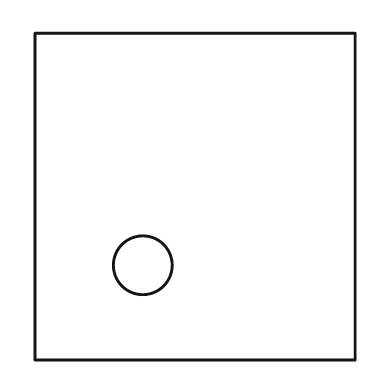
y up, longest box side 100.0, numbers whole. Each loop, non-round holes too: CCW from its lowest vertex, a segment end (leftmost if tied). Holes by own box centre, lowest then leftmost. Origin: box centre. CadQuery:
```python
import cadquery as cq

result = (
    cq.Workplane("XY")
    .moveTo(-49.0, -50.0)
    .lineTo(49.0, -50.0)
    .lineTo(49.0, 50.0)
    .lineTo(-49.0, 50.0)
    .close()
    .moveTo(-16.0, -21.0)
    .circle(9.0)
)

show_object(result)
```